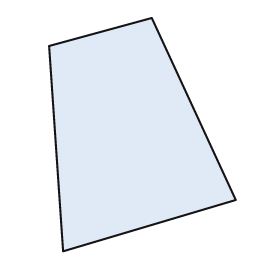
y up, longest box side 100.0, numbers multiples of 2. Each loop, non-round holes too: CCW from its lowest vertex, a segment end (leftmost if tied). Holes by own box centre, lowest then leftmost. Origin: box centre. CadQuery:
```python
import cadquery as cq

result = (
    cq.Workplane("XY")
    .moveTo(-34.0, -50.0)
    .lineTo(40.0, -28.0)
    .lineTo(4.0, 50.0)
    .lineTo(-40.0, 38.0)
    .close()
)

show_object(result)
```